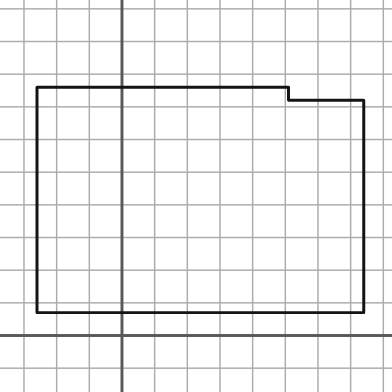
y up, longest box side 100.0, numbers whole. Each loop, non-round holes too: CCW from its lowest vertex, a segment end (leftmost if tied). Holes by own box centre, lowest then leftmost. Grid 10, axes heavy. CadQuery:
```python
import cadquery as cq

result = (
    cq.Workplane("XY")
    .moveTo(-26.0, 7.0)
    .lineTo(74.0, 7.0)
    .lineTo(74.0, 72.0)
    .lineTo(51.0, 72.0)
    .lineTo(51.0, 76.0)
    .lineTo(-26.0, 76.0)
    .close()
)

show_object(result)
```